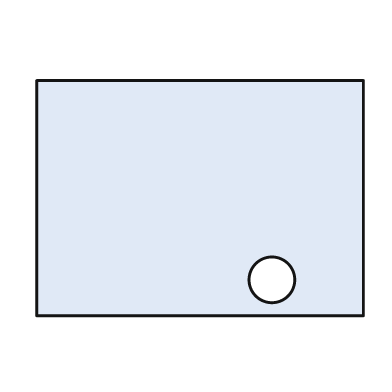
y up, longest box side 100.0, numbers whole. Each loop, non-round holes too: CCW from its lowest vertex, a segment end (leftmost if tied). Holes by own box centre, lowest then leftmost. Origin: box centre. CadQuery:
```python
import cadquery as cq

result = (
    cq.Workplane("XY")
    .moveTo(-50.0, -36.0)
    .lineTo(50.0, -36.0)
    .lineTo(50.0, 36.0)
    .lineTo(-50.0, 36.0)
    .close()
    .moveTo(22.0, -25.0)
    .circle(7.0)
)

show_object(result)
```